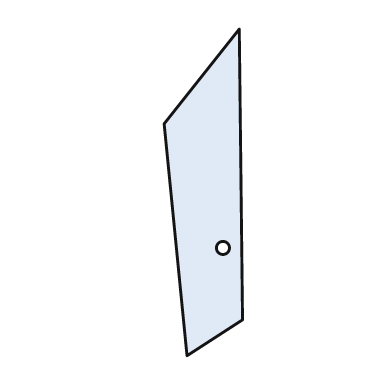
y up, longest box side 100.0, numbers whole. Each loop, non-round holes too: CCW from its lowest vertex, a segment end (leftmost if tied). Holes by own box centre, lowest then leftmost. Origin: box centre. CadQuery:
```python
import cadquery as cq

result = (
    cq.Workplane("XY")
    .moveTo(-5.0, -50.0)
    .lineTo(12.0, -39.0)
    .lineTo(11.0, 50.0)
    .lineTo(-12.0, 21.0)
    .close()
    .moveTo(6.0, -17.0)
    .circle(2.0)
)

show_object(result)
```